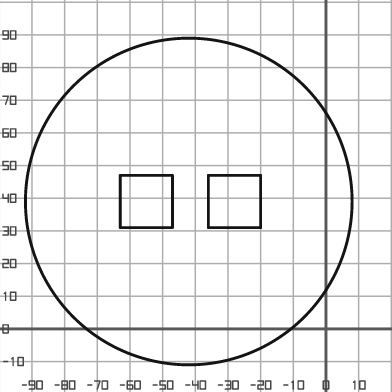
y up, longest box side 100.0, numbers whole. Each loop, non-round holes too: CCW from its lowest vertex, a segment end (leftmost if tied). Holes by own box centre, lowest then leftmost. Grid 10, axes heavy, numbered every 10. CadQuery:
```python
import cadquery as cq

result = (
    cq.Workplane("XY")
    .moveTo(-42.0, 39.0)
    .circle(50.0)
    .moveTo(-63.0, 31.0)
    .lineTo(-47.0, 31.0)
    .lineTo(-47.0, 47.0)
    .lineTo(-63.0, 47.0)
    .close()
    .moveTo(-36.0, 31.0)
    .lineTo(-20.0, 31.0)
    .lineTo(-20.0, 47.0)
    .lineTo(-36.0, 47.0)
    .close()
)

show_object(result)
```